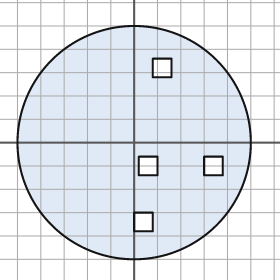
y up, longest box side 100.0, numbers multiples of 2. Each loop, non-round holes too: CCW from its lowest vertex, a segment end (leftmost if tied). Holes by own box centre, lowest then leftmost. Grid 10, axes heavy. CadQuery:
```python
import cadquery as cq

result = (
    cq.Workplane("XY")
    .moveTo(0.0, 0.0)
    .circle(50.0)
    .moveTo(0.0, -38.0)
    .lineTo(8.0, -38.0)
    .lineTo(8.0, -30.0)
    .lineTo(0.0, -30.0)
    .close()
    .moveTo(2.0, -14.0)
    .lineTo(10.0, -14.0)
    .lineTo(10.0, -6.0)
    .lineTo(2.0, -6.0)
    .close()
    .moveTo(30.0, -14.0)
    .lineTo(38.0, -14.0)
    .lineTo(38.0, -6.0)
    .lineTo(30.0, -6.0)
    .close()
    .moveTo(8.0, 28.0)
    .lineTo(16.0, 28.0)
    .lineTo(16.0, 36.0)
    .lineTo(8.0, 36.0)
    .close()
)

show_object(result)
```